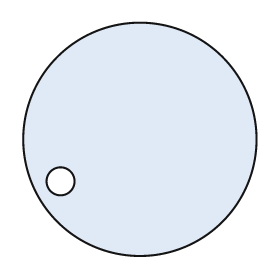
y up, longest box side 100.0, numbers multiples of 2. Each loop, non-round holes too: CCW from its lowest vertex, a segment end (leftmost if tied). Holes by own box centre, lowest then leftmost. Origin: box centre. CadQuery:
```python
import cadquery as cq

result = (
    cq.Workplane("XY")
    .moveTo(0.0, 0.0)
    .circle(50.0)
    .moveTo(-34.0, -18.0)
    .circle(6.0)
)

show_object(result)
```